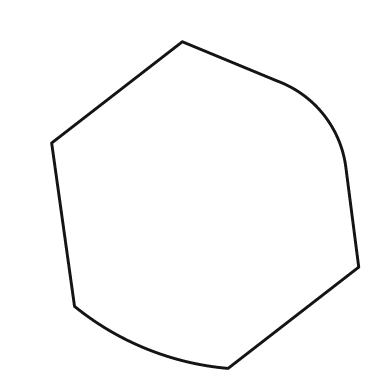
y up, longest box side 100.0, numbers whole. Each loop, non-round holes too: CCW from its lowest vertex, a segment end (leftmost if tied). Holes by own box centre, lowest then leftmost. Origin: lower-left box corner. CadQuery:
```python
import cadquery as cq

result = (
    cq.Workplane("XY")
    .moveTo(54.0, 0.0)
    .lineTo(94.0, 31.0)
    .lineTo(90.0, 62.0)
    .threePointArc((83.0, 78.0), (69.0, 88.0))
    .lineTo(40.0, 100.0)
    .lineTo(0.0, 69.0)
    .lineTo(7.0, 19.0)
    .threePointArc((29.0, 6.0), (54.0, 0.0))
    .close()
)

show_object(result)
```